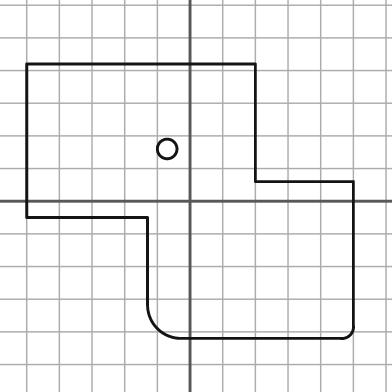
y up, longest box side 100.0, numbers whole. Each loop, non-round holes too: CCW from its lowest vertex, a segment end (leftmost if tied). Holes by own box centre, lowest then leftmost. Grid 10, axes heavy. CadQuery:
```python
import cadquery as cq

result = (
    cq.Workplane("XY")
    .moveTo(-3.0, -42.0)
    .lineTo(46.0, -42.0)
    .threePointArc((49.0, -41.0), (50.0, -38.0))
    .lineTo(50.0, 6.0)
    .lineTo(20.0, 6.0)
    .lineTo(20.0, 42.0)
    .lineTo(-50.0, 42.0)
    .lineTo(-50.0, -5.0)
    .lineTo(-13.0, -5.0)
    .lineTo(-13.0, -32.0)
    .threePointArc((-10.0, -39.0), (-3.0, -42.0))
    .close()
    .moveTo(-7.0, 16.0)
    .circle(3.0)
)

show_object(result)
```